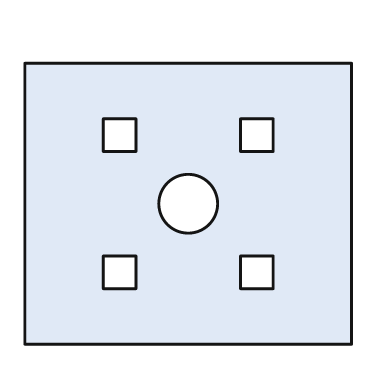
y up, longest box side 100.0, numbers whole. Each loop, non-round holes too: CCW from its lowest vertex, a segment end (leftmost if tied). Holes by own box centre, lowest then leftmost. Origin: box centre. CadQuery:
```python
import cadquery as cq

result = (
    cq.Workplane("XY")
    .moveTo(-50.0, -43.0)
    .lineTo(50.0, -43.0)
    .lineTo(50.0, 43.0)
    .lineTo(-50.0, 43.0)
    .close()
    .moveTo(-26.0, -26.0)
    .lineTo(-16.0, -26.0)
    .lineTo(-16.0, -16.0)
    .lineTo(-26.0, -16.0)
    .close()
    .moveTo(16.0, -26.0)
    .lineTo(26.0, -26.0)
    .lineTo(26.0, -16.0)
    .lineTo(16.0, -16.0)
    .close()
    .moveTo(0.0, 0.0)
    .circle(9.0)
    .moveTo(-26.0, 16.0)
    .lineTo(-16.0, 16.0)
    .lineTo(-16.0, 26.0)
    .lineTo(-26.0, 26.0)
    .close()
    .moveTo(16.0, 16.0)
    .lineTo(26.0, 16.0)
    .lineTo(26.0, 26.0)
    .lineTo(16.0, 26.0)
    .close()
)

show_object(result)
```